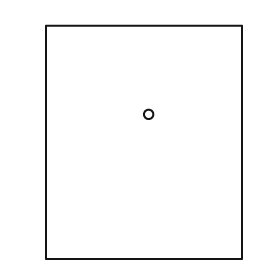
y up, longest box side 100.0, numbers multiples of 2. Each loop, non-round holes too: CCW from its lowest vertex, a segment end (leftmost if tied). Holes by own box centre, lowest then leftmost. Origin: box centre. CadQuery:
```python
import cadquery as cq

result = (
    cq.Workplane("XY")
    .moveTo(-42.0, -50.0)
    .lineTo(42.0, -50.0)
    .lineTo(42.0, 50.0)
    .lineTo(-42.0, 50.0)
    .close()
    .moveTo(2.0, 12.0)
    .circle(2.0)
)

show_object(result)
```